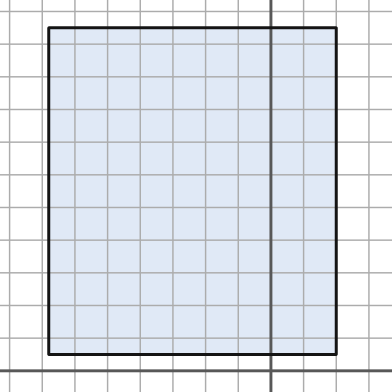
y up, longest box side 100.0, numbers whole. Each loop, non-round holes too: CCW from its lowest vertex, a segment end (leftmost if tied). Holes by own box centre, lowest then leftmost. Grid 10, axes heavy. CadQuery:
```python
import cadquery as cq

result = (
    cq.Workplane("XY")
    .moveTo(-68.0, 5.0)
    .lineTo(20.0, 5.0)
    .lineTo(20.0, 105.0)
    .lineTo(-68.0, 105.0)
    .close()
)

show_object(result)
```